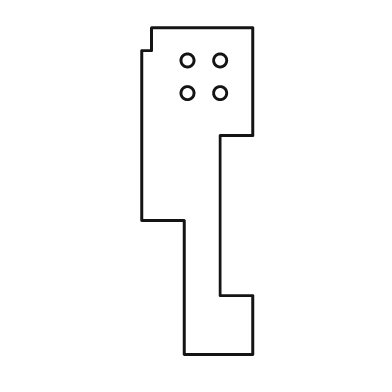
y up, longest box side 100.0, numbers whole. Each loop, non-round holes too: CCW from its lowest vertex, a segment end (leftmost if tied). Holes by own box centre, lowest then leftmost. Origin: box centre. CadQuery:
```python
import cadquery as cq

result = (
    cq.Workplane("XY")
    .moveTo(-4.0, -50.0)
    .lineTo(17.0, -50.0)
    .lineTo(17.0, -32.0)
    .lineTo(7.0, -32.0)
    .lineTo(7.0, 17.0)
    .lineTo(17.0, 17.0)
    .lineTo(17.0, 50.0)
    .lineTo(-14.0, 50.0)
    .lineTo(-14.0, 43.0)
    .lineTo(-17.0, 43.0)
    .lineTo(-17.0, -9.0)
    .lineTo(-4.0, -9.0)
    .close()
    .moveTo(-3.0, 30.0)
    .circle(2.0)
    .moveTo(7.0, 30.0)
    .circle(2.0)
    .moveTo(-3.0, 40.0)
    .circle(2.0)
    .moveTo(7.0, 40.0)
    .circle(2.0)
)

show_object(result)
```